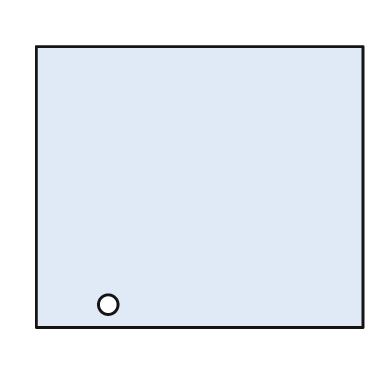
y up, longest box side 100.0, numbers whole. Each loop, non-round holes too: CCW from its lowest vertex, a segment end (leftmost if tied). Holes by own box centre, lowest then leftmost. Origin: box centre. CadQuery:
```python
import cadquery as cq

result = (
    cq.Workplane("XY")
    .moveTo(-50.0, -43.0)
    .lineTo(50.0, -43.0)
    .lineTo(50.0, 43.0)
    .lineTo(-50.0, 43.0)
    .close()
    .moveTo(-28.0, -36.0)
    .circle(3.0)
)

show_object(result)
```